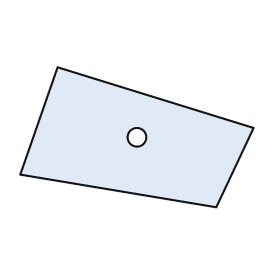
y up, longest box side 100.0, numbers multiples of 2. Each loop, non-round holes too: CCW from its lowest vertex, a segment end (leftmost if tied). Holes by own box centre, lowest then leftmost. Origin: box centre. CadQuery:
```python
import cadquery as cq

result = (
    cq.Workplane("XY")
    .moveTo(34.0, -30.0)
    .lineTo(50.0, 4.0)
    .lineTo(-34.0, 30.0)
    .lineTo(-50.0, -16.0)
    .close()
    .moveTo(0.0, 0.0)
    .circle(4.0)
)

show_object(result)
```